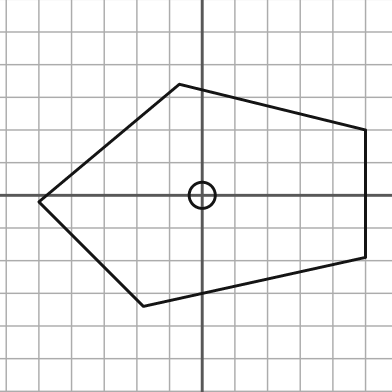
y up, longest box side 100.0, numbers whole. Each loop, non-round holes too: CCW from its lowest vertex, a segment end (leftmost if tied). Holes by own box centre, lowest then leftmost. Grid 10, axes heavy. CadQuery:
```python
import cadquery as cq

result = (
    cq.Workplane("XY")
    .moveTo(-18.0, -34.0)
    .lineTo(50.0, -19.0)
    .lineTo(50.0, 20.0)
    .lineTo(-7.0, 34.0)
    .lineTo(-50.0, -2.0)
    .close()
    .moveTo(0.0, 0.0)
    .circle(4.0)
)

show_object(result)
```